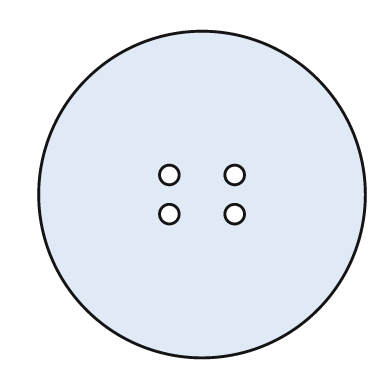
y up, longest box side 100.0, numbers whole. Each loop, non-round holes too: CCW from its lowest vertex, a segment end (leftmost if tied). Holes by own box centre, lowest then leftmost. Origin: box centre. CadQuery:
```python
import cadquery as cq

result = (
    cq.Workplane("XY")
    .moveTo(0.0, 0.0)
    .circle(50.0)
    .moveTo(-10.0, -6.0)
    .circle(3.0)
    .moveTo(10.0, -6.0)
    .circle(3.0)
    .moveTo(-10.0, 6.0)
    .circle(3.0)
    .moveTo(10.0, 6.0)
    .circle(3.0)
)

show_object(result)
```